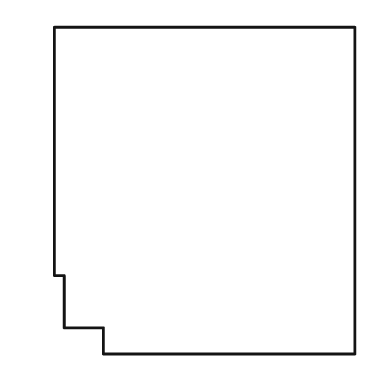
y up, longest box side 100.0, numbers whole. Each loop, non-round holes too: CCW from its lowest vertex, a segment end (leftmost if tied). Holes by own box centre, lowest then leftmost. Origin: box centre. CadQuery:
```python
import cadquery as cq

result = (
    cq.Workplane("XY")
    .moveTo(-31.0, -50.0)
    .lineTo(46.0, -50.0)
    .lineTo(46.0, 50.0)
    .lineTo(-46.0, 50.0)
    .lineTo(-46.0, -26.0)
    .lineTo(-43.0, -26.0)
    .lineTo(-43.0, -42.0)
    .lineTo(-31.0, -42.0)
    .close()
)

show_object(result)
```